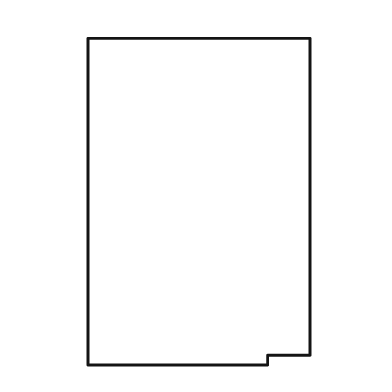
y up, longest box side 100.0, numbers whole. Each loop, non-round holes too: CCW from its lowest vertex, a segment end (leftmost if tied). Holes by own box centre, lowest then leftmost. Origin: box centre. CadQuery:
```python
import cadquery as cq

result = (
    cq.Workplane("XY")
    .moveTo(-34.0, -50.0)
    .lineTo(21.0, -50.0)
    .lineTo(21.0, -47.0)
    .lineTo(34.0, -47.0)
    .lineTo(34.0, 50.0)
    .lineTo(-34.0, 50.0)
    .close()
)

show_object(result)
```